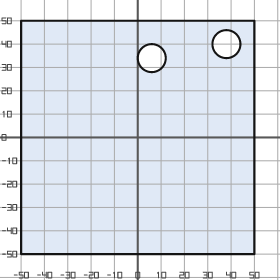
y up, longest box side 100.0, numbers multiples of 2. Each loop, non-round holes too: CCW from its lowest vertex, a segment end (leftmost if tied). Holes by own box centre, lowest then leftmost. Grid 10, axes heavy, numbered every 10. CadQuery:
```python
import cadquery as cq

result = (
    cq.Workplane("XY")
    .moveTo(-50.0, -50.0)
    .lineTo(50.0, -50.0)
    .lineTo(50.0, 50.0)
    .lineTo(-50.0, 50.0)
    .close()
    .moveTo(6.0, 34.0)
    .circle(6.0)
    .moveTo(38.0, 40.0)
    .circle(6.0)
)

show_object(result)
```